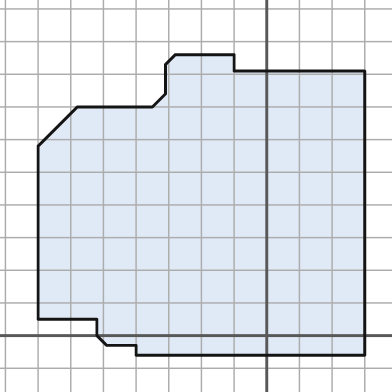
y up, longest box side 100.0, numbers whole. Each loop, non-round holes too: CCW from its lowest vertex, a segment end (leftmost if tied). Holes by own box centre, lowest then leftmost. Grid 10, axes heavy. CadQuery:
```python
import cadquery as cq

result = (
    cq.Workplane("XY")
    .moveTo(-40.0, -6.0)
    .lineTo(30.0, -6.0)
    .lineTo(30.0, 81.0)
    .lineTo(-10.0, 81.0)
    .lineTo(-10.0, 86.0)
    .lineTo(-28.0, 86.0)
    .lineTo(-31.0, 83.0)
    .lineTo(-31.0, 74.0)
    .lineTo(-35.0, 70.0)
    .lineTo(-58.0, 70.0)
    .lineTo(-70.0, 58.0)
    .lineTo(-70.0, 5.0)
    .lineTo(-52.0, 5.0)
    .lineTo(-52.0, 0.0)
    .lineTo(-49.0, -3.0)
    .lineTo(-40.0, -3.0)
    .close()
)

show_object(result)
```